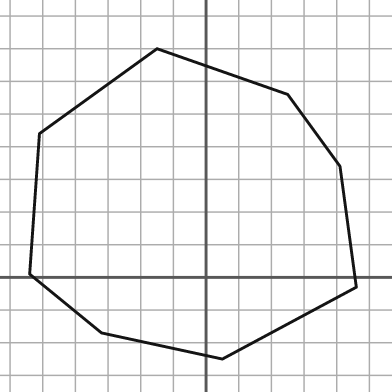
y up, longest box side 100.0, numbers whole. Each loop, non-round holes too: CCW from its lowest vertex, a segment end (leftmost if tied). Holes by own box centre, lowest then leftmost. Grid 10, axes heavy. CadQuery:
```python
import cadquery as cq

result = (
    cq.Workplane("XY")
    .moveTo(5.0, -25.0)
    .lineTo(46.0, -3.0)
    .lineTo(41.0, 34.0)
    .lineTo(25.0, 56.0)
    .lineTo(-15.0, 70.0)
    .lineTo(-51.0, 44.0)
    .lineTo(-54.0, 1.0)
    .lineTo(-32.0, -17.0)
    .close()
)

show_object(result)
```